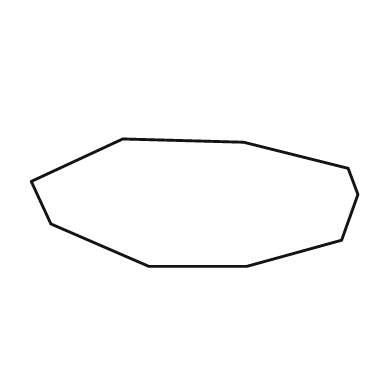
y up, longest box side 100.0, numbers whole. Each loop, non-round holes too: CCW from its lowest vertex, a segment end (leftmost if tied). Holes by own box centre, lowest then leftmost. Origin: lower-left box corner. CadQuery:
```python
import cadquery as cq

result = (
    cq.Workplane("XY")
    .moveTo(36.0, 0.0)
    .lineTo(66.0, 0.0)
    .lineTo(95.0, 8.0)
    .lineTo(100.0, 22.0)
    .lineTo(97.0, 30.0)
    .lineTo(65.0, 38.0)
    .lineTo(28.0, 39.0)
    .lineTo(0.0, 26.0)
    .lineTo(6.0, 13.0)
    .close()
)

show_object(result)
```